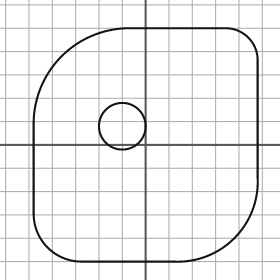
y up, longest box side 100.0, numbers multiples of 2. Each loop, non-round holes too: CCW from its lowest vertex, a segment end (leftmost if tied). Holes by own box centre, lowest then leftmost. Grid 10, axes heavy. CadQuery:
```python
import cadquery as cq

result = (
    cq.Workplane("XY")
    .moveTo(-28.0, -50.0)
    .lineTo(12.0, -50.0)
    .threePointArc((38.0, -40.0), (48.0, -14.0))
    .lineTo(48.0, 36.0)
    .threePointArc((44.0, 46.0), (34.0, 50.0))
    .lineTo(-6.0, 50.0)
    .threePointArc((-36.0, 38.0), (-48.0, 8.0))
    .lineTo(-48.0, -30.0)
    .threePointArc((-42.0, -44.0), (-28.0, -50.0))
    .close()
    .moveTo(-10.0, 8.0)
    .circle(10.0)
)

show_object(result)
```